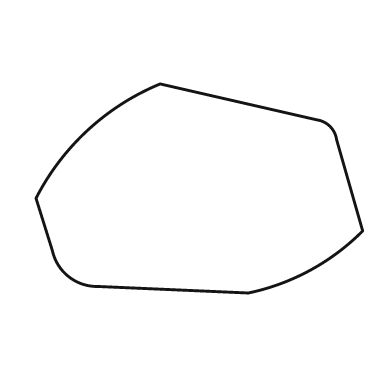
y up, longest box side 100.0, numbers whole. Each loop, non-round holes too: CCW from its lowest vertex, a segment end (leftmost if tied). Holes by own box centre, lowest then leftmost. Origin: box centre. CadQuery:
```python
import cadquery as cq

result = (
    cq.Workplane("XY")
    .moveTo(15.0, -32.0)
    .threePointArc((34.0, -25.0), (50.0, -13.0))
    .lineTo(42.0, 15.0)
    .threePointArc((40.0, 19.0), (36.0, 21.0))
    .lineTo(-12.0, 32.0)
    .threePointArc((-34.0, 18.0), (-50.0, -3.0))
    .lineTo(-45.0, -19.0)
    .threePointArc((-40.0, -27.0), (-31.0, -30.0))
    .close()
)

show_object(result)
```